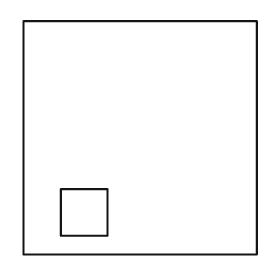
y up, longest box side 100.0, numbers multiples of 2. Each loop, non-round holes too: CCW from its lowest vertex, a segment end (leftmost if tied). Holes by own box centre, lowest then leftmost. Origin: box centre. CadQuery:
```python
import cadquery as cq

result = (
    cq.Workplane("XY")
    .moveTo(-50.0, -50.0)
    .lineTo(50.0, -50.0)
    .lineTo(50.0, 50.0)
    .lineTo(-50.0, 50.0)
    .close()
    .moveTo(-34.0, -42.0)
    .lineTo(-14.0, -42.0)
    .lineTo(-14.0, -22.0)
    .lineTo(-34.0, -22.0)
    .close()
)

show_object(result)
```